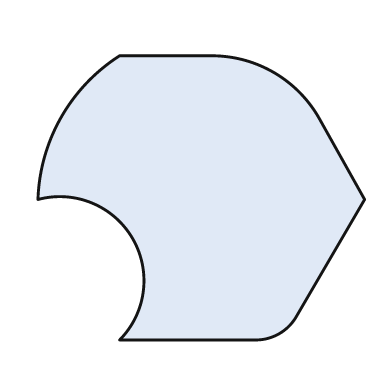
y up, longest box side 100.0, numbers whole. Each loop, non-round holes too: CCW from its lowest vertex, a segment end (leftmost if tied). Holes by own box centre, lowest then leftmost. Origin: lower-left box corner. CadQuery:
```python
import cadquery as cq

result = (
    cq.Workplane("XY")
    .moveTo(25.0, 0.0)
    .lineTo(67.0, 0.0)
    .threePointArc((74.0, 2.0), (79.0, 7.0))
    .lineTo(100.0, 43.0)
    .lineTo(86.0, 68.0)
    .threePointArc((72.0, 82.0), (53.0, 87.0))
    .lineTo(25.0, 87.0)
    .threePointArc((7.0, 68.0), (0.0, 43.0))
    .threePointArc((29.0, 31.0), (25.0, 0.0))
    .close()
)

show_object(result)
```